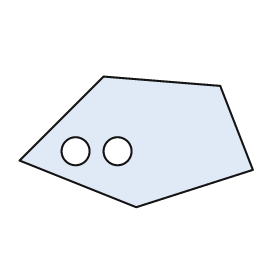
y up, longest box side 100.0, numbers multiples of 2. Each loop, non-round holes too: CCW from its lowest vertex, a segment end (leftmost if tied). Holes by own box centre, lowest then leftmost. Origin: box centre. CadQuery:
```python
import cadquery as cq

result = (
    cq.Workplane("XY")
    .moveTo(0.0, -28.0)
    .lineTo(50.0, -12.0)
    .lineTo(36.0, 24.0)
    .lineTo(-14.0, 28.0)
    .lineTo(-50.0, -8.0)
    .close()
    .moveTo(-26.0, -4.0)
    .circle(6.0)
    .moveTo(-8.0, -4.0)
    .circle(6.0)
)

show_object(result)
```